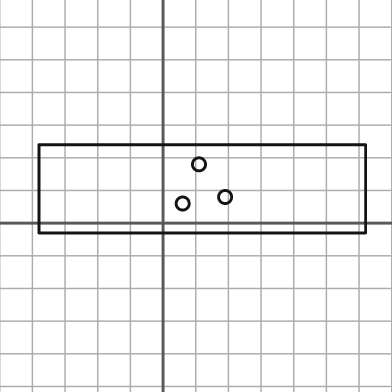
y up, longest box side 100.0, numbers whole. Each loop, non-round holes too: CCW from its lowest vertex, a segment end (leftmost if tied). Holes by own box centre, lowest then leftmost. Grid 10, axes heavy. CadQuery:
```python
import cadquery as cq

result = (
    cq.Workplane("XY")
    .moveTo(-38.0, -3.0)
    .lineTo(62.0, -3.0)
    .lineTo(62.0, 24.0)
    .lineTo(-38.0, 24.0)
    .close()
    .moveTo(6.0, 6.0)
    .circle(2.0)
    .moveTo(19.0, 8.0)
    .circle(2.0)
    .moveTo(11.0, 18.0)
    .circle(2.0)
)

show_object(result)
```